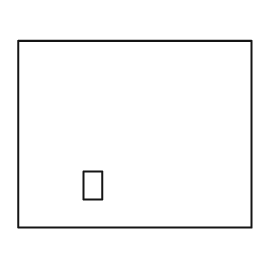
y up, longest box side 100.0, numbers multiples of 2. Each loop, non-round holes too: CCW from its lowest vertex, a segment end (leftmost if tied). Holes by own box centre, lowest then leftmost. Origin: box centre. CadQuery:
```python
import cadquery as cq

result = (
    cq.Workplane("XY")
    .moveTo(-50.0, -40.0)
    .lineTo(50.0, -40.0)
    .lineTo(50.0, 40.0)
    .lineTo(-50.0, 40.0)
    .close()
    .moveTo(-22.0, -28.0)
    .lineTo(-14.0, -28.0)
    .lineTo(-14.0, -16.0)
    .lineTo(-22.0, -16.0)
    .close()
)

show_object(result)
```